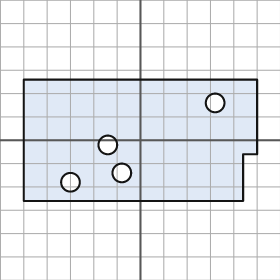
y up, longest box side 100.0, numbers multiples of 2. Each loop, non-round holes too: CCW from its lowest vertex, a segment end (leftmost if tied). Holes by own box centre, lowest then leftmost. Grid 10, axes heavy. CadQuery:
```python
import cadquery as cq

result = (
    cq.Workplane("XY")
    .moveTo(-50.0, -26.0)
    .lineTo(44.0, -26.0)
    .lineTo(44.0, -6.0)
    .lineTo(50.0, -6.0)
    .lineTo(50.0, 26.0)
    .lineTo(-50.0, 26.0)
    .close()
    .moveTo(-30.0, -18.0)
    .circle(4.0)
    .moveTo(-8.0, -14.0)
    .circle(4.0)
    .moveTo(-14.0, -2.0)
    .circle(4.0)
    .moveTo(32.0, 16.0)
    .circle(4.0)
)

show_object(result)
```